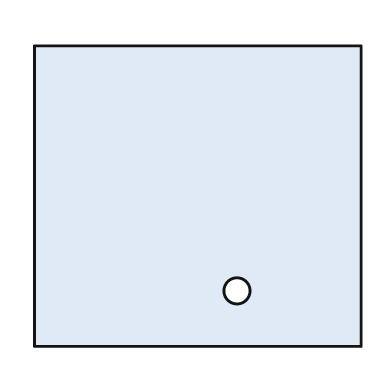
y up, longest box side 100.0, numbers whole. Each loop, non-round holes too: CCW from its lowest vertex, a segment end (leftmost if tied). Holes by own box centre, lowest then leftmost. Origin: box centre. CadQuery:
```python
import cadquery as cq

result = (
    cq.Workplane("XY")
    .moveTo(-50.0, -46.0)
    .lineTo(50.0, -46.0)
    .lineTo(50.0, 46.0)
    .lineTo(-50.0, 46.0)
    .close()
    .moveTo(12.0, -29.0)
    .circle(4.0)
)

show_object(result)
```